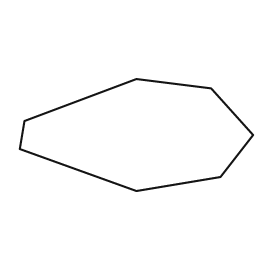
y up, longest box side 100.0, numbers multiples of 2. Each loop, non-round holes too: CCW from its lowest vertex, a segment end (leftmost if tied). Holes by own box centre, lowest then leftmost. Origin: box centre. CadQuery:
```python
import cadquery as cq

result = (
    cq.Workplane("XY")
    .moveTo(0.0, -24.0)
    .lineTo(36.0, -18.0)
    .lineTo(50.0, 0.0)
    .lineTo(32.0, 20.0)
    .lineTo(0.0, 24.0)
    .lineTo(-48.0, 6.0)
    .lineTo(-50.0, -6.0)
    .close()
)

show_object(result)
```